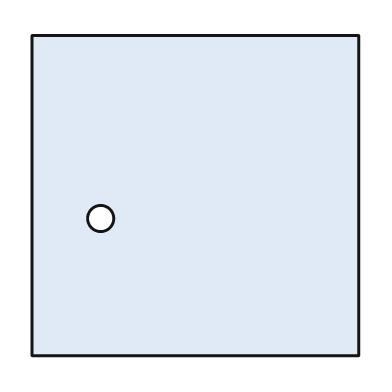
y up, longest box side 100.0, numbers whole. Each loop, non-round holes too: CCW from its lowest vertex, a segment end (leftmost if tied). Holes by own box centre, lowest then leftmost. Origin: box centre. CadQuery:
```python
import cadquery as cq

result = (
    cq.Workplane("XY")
    .moveTo(-50.0, -49.0)
    .lineTo(50.0, -49.0)
    .lineTo(50.0, 49.0)
    .lineTo(-50.0, 49.0)
    .close()
    .moveTo(-29.0, -7.0)
    .circle(4.0)
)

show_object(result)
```